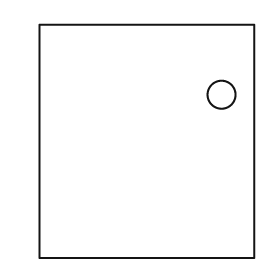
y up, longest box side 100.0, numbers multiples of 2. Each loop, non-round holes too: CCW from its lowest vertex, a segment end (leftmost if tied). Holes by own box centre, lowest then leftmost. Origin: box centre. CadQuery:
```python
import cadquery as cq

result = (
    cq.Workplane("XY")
    .moveTo(-46.0, -50.0)
    .lineTo(46.0, -50.0)
    .lineTo(46.0, 50.0)
    .lineTo(-46.0, 50.0)
    .close()
    .moveTo(32.0, 20.0)
    .circle(6.0)
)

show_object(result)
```